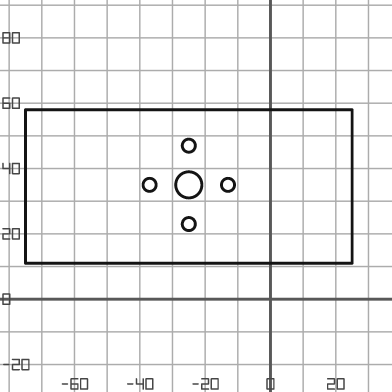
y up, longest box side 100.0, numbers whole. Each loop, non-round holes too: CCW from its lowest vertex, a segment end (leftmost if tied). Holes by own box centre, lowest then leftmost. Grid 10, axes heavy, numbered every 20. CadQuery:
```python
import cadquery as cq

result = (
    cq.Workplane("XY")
    .moveTo(-75.0, 11.0)
    .lineTo(25.0, 11.0)
    .lineTo(25.0, 58.0)
    .lineTo(-75.0, 58.0)
    .close()
    .moveTo(-25.0, 23.0)
    .circle(2.0)
    .moveTo(-37.0, 35.0)
    .circle(2.0)
    .moveTo(-25.0, 35.0)
    .circle(4.0)
    .moveTo(-13.0, 35.0)
    .circle(2.0)
    .moveTo(-25.0, 47.0)
    .circle(2.0)
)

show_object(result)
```